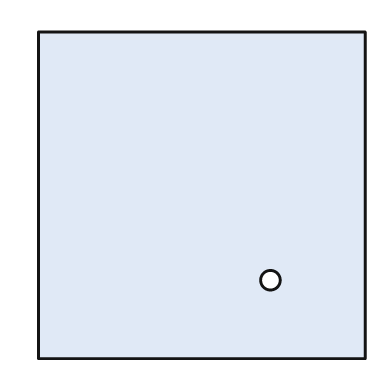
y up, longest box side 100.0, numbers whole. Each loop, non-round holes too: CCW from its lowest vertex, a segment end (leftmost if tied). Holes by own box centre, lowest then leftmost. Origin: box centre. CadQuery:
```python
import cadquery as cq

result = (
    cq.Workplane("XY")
    .moveTo(-50.0, -50.0)
    .lineTo(50.0, -50.0)
    .lineTo(50.0, 50.0)
    .lineTo(-50.0, 50.0)
    .close()
    .moveTo(21.0, -26.0)
    .circle(3.0)
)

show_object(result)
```